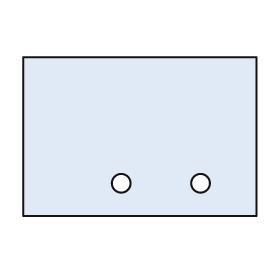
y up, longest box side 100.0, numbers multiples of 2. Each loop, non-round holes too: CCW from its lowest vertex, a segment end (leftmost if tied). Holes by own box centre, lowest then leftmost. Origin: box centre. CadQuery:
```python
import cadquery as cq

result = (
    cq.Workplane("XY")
    .moveTo(-50.0, -34.0)
    .lineTo(50.0, -34.0)
    .lineTo(50.0, 34.0)
    .lineTo(-50.0, 34.0)
    .close()
    .moveTo(-8.0, -20.0)
    .circle(4.0)
    .moveTo(26.0, -20.0)
    .circle(4.0)
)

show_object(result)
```